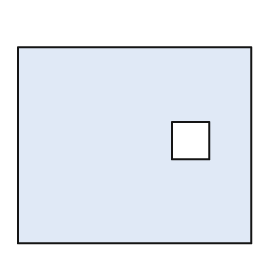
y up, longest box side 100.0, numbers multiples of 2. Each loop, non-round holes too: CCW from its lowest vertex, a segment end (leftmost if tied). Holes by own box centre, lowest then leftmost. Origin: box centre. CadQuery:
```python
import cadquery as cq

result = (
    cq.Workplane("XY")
    .moveTo(-50.0, -42.0)
    .lineTo(50.0, -42.0)
    .lineTo(50.0, 42.0)
    .lineTo(-50.0, 42.0)
    .close()
    .moveTo(16.0, -6.0)
    .lineTo(32.0, -6.0)
    .lineTo(32.0, 10.0)
    .lineTo(16.0, 10.0)
    .close()
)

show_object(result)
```